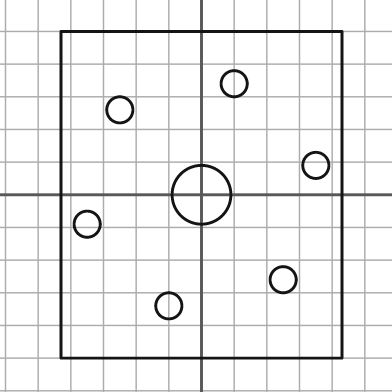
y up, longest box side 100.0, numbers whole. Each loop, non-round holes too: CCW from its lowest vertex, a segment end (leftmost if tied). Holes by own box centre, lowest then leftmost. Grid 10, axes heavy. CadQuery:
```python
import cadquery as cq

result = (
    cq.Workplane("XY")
    .moveTo(-43.0, -50.0)
    .lineTo(43.0, -50.0)
    .lineTo(43.0, 50.0)
    .lineTo(-43.0, 50.0)
    .close()
    .moveTo(-10.0, -34.0)
    .circle(4.0)
    .moveTo(25.0, -26.0)
    .circle(4.0)
    .moveTo(-35.0, -9.0)
    .circle(4.0)
    .moveTo(0.0, 0.0)
    .circle(9.0)
    .moveTo(35.0, 9.0)
    .circle(4.0)
    .moveTo(-25.0, 26.0)
    .circle(4.0)
    .moveTo(10.0, 34.0)
    .circle(4.0)
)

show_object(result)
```